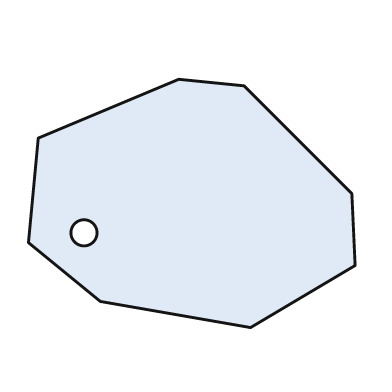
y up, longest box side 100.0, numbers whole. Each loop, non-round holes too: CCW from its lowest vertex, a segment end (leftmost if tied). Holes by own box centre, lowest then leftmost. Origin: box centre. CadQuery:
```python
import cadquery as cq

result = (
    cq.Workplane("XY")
    .moveTo(18.0, -38.0)
    .lineTo(50.0, -19.0)
    .lineTo(49.0, 3.0)
    .lineTo(16.0, 36.0)
    .lineTo(-4.0, 38.0)
    .lineTo(-47.0, 20.0)
    .lineTo(-50.0, -12.0)
    .lineTo(-28.0, -30.0)
    .close()
    .moveTo(-33.0, -9.0)
    .circle(4.0)
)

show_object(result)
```